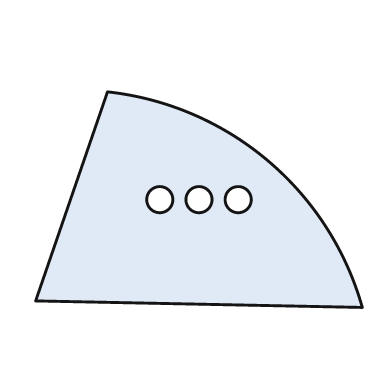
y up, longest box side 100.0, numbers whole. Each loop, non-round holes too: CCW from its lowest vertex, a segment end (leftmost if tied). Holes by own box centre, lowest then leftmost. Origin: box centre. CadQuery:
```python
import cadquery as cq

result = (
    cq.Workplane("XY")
    .moveTo(50.0, -33.0)
    .threePointArc((21.0, 12.0), (-28.0, 33.0))
    .lineTo(-50.0, -31.0)
    .close()
    .moveTo(-12.0, 0.0)
    .circle(4.0)
    .moveTo(0.0, 0.0)
    .circle(4.0)
    .moveTo(12.0, 0.0)
    .circle(4.0)
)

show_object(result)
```